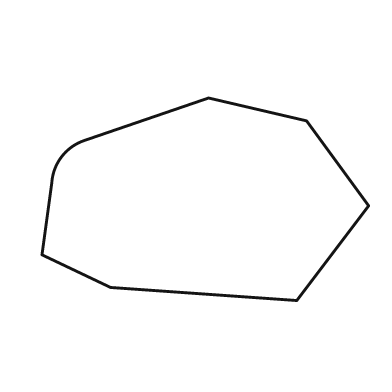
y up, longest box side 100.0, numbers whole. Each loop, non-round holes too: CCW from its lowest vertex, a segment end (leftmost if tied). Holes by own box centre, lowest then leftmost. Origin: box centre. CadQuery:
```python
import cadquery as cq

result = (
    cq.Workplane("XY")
    .moveTo(28.0, -31.0)
    .lineTo(50.0, -2.0)
    .lineTo(31.0, 24.0)
    .lineTo(1.0, 31.0)
    .lineTo(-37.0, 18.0)
    .threePointArc((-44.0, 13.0), (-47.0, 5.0))
    .lineTo(-50.0, -17.0)
    .lineTo(-29.0, -27.0)
    .close()
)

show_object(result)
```